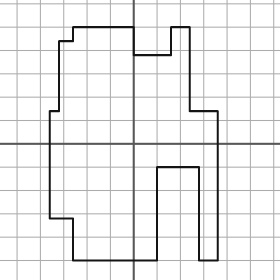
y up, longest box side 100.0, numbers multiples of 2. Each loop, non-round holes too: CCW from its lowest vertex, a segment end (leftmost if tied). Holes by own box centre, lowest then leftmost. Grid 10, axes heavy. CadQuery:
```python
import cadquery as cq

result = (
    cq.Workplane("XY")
    .moveTo(-26.0, -50.0)
    .lineTo(10.0, -50.0)
    .lineTo(10.0, -10.0)
    .lineTo(28.0, -10.0)
    .lineTo(28.0, -50.0)
    .lineTo(36.0, -50.0)
    .lineTo(36.0, 14.0)
    .lineTo(24.0, 14.0)
    .lineTo(24.0, 50.0)
    .lineTo(16.0, 50.0)
    .lineTo(16.0, 38.0)
    .lineTo(0.0, 38.0)
    .lineTo(0.0, 50.0)
    .lineTo(-26.0, 50.0)
    .lineTo(-26.0, 44.0)
    .lineTo(-32.0, 44.0)
    .lineTo(-32.0, 14.0)
    .lineTo(-36.0, 14.0)
    .lineTo(-36.0, -32.0)
    .lineTo(-26.0, -32.0)
    .close()
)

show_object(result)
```